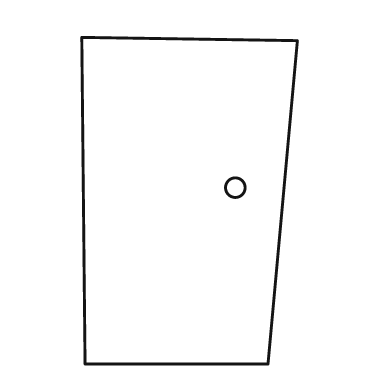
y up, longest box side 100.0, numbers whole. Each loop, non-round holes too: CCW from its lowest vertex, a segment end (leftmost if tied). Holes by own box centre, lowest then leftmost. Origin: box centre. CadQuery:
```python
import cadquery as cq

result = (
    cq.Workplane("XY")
    .moveTo(-32.0, -50.0)
    .lineTo(24.0, -50.0)
    .lineTo(33.0, 49.0)
    .lineTo(-33.0, 50.0)
    .close()
    .moveTo(14.0, 4.0)
    .circle(3.0)
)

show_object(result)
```